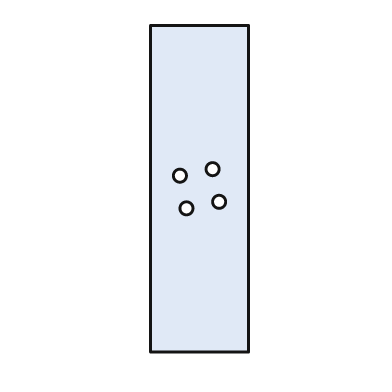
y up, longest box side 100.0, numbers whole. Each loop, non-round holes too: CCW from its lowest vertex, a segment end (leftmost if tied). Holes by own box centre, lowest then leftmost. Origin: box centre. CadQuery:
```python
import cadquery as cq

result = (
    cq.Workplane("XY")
    .moveTo(-15.0, -50.0)
    .lineTo(15.0, -50.0)
    .lineTo(15.0, 50.0)
    .lineTo(-15.0, 50.0)
    .close()
    .moveTo(-4.0, -6.0)
    .circle(2.0)
    .moveTo(6.0, -4.0)
    .circle(2.0)
    .moveTo(-6.0, 4.0)
    .circle(2.0)
    .moveTo(4.0, 6.0)
    .circle(2.0)
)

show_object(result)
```